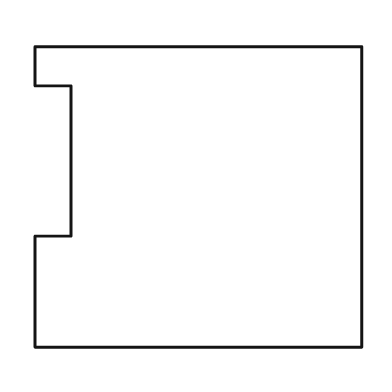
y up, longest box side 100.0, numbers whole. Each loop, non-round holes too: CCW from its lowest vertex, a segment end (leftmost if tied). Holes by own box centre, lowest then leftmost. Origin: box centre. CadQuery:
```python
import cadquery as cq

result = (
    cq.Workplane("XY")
    .moveTo(-50.0, -46.0)
    .lineTo(50.0, -46.0)
    .lineTo(50.0, 46.0)
    .lineTo(-50.0, 46.0)
    .lineTo(-50.0, 34.0)
    .lineTo(-39.0, 34.0)
    .lineTo(-39.0, -12.0)
    .lineTo(-50.0, -12.0)
    .close()
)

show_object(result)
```